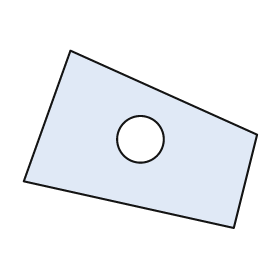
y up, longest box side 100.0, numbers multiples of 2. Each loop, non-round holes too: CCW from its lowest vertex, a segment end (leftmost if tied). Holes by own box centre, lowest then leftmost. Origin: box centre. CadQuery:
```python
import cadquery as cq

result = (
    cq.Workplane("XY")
    .moveTo(40.0, -38.0)
    .lineTo(50.0, 2.0)
    .lineTo(-30.0, 38.0)
    .lineTo(-50.0, -18.0)
    .close()
    .moveTo(0.0, 0.0)
    .circle(10.0)
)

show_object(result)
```